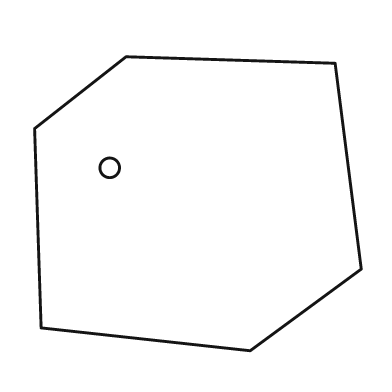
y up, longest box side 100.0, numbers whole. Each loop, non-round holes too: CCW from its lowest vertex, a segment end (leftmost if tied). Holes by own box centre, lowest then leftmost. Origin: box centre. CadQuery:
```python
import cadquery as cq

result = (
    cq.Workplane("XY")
    .moveTo(16.0, -45.0)
    .lineTo(50.0, -20.0)
    .lineTo(42.0, 43.0)
    .lineTo(-22.0, 45.0)
    .lineTo(-50.0, 23.0)
    .lineTo(-48.0, -38.0)
    .close()
    .moveTo(-27.0, 11.0)
    .circle(3.0)
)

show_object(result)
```